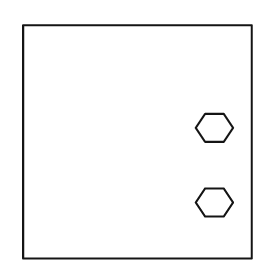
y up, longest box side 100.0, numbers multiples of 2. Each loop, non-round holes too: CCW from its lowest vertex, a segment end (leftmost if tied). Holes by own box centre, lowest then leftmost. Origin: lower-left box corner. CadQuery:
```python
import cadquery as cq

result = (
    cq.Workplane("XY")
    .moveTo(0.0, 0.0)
    .lineTo(98.0, 0.0)
    .lineTo(98.0, 100.0)
    .lineTo(0.0, 100.0)
    .close()
    .moveTo(78.0, 18.0)
    .lineTo(86.0, 18.0)
    .lineTo(90.0, 24.0)
    .lineTo(86.0, 30.0)
    .lineTo(78.0, 30.0)
    .lineTo(74.0, 24.0)
    .close()
    .moveTo(78.0, 50.0)
    .lineTo(86.0, 50.0)
    .lineTo(90.0, 56.0)
    .lineTo(86.0, 62.0)
    .lineTo(78.0, 62.0)
    .lineTo(74.0, 56.0)
    .close()
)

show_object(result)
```